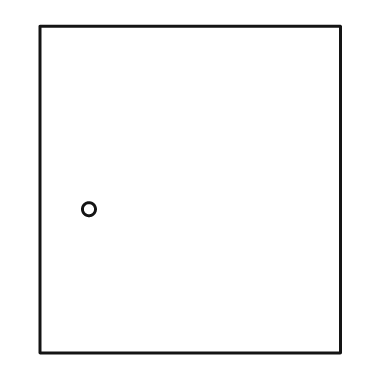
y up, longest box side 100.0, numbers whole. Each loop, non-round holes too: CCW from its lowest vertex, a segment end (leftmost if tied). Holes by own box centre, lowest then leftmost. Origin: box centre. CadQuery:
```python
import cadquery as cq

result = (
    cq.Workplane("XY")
    .moveTo(-46.0, -50.0)
    .lineTo(46.0, -50.0)
    .lineTo(46.0, 50.0)
    .lineTo(-46.0, 50.0)
    .close()
    .moveTo(-31.0, -6.0)
    .circle(2.0)
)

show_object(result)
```